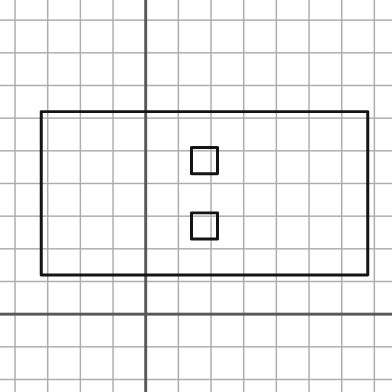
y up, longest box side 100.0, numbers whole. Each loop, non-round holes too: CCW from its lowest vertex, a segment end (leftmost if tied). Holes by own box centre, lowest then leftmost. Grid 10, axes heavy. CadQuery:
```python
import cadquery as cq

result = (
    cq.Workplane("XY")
    .moveTo(-32.0, 12.0)
    .lineTo(68.0, 12.0)
    .lineTo(68.0, 62.0)
    .lineTo(-32.0, 62.0)
    .close()
    .moveTo(14.0, 23.0)
    .lineTo(22.0, 23.0)
    .lineTo(22.0, 31.0)
    .lineTo(14.0, 31.0)
    .close()
    .moveTo(14.0, 43.0)
    .lineTo(22.0, 43.0)
    .lineTo(22.0, 51.0)
    .lineTo(14.0, 51.0)
    .close()
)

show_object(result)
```